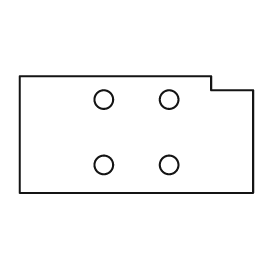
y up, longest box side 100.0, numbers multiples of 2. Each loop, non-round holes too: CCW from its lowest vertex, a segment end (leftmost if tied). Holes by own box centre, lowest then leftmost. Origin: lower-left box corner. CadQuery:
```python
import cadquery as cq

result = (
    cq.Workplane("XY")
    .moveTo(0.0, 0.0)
    .lineTo(100.0, 0.0)
    .lineTo(100.0, 44.0)
    .lineTo(82.0, 44.0)
    .lineTo(82.0, 50.0)
    .lineTo(0.0, 50.0)
    .close()
    .moveTo(36.0, 12.0)
    .circle(4.0)
    .moveTo(64.0, 12.0)
    .circle(4.0)
    .moveTo(36.0, 40.0)
    .circle(4.0)
    .moveTo(64.0, 40.0)
    .circle(4.0)
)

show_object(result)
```